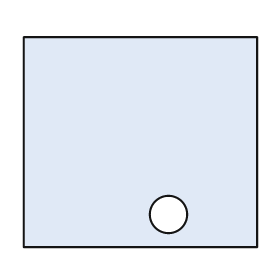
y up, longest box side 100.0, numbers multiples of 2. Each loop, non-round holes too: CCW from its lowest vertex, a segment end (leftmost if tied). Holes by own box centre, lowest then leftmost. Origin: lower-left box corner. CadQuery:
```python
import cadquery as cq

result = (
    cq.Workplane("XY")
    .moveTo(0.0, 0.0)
    .lineTo(100.0, 0.0)
    .lineTo(100.0, 90.0)
    .lineTo(0.0, 90.0)
    .close()
    .moveTo(62.0, 14.0)
    .circle(8.0)
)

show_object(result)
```